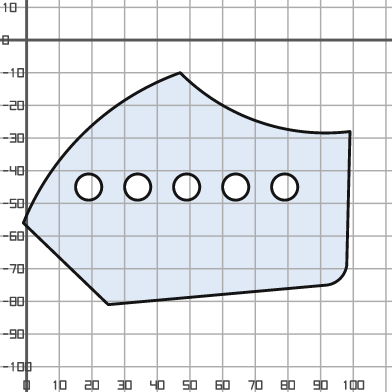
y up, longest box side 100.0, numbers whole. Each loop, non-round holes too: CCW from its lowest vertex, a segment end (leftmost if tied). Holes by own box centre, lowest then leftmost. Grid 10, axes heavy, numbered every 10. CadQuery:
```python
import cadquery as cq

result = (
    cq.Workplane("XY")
    .moveTo(25.0, -81.0)
    .lineTo(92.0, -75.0)
    .threePointArc((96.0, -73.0), (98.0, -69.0))
    .lineTo(99.0, -28.0)
    .threePointArc((71.0, -25.0), (47.0, -10.0))
    .threePointArc((18.0, -28.0), (-1.0, -56.0))
    .close()
    .moveTo(19.0, -45.0)
    .circle(4.0)
    .moveTo(34.0, -45.0)
    .circle(4.0)
    .moveTo(49.0, -45.0)
    .circle(4.0)
    .moveTo(64.0, -45.0)
    .circle(4.0)
    .moveTo(79.0, -45.0)
    .circle(4.0)
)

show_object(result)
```